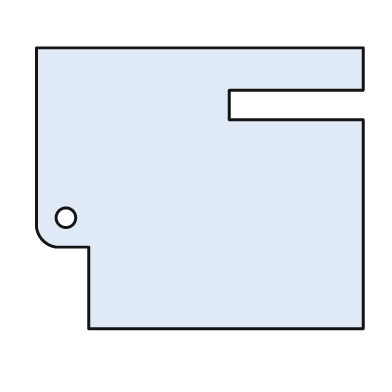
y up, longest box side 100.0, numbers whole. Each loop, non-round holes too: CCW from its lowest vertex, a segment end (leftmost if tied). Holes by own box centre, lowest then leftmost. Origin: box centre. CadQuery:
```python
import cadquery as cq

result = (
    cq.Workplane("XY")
    .moveTo(-34.0, -43.0)
    .lineTo(50.0, -43.0)
    .lineTo(50.0, 21.0)
    .lineTo(9.0, 21.0)
    .lineTo(9.0, 30.0)
    .lineTo(50.0, 30.0)
    .lineTo(50.0, 43.0)
    .lineTo(-50.0, 43.0)
    .lineTo(-50.0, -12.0)
    .threePointArc((-48.0, -16.0), (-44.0, -18.0))
    .lineTo(-34.0, -18.0)
    .close()
    .moveTo(-41.0, -9.0)
    .circle(3.0)
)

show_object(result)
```